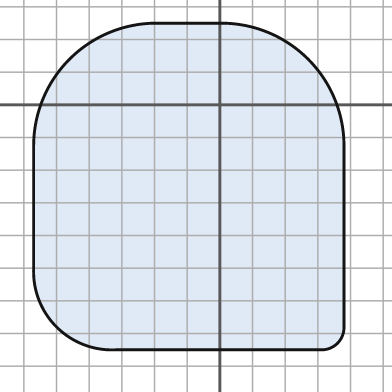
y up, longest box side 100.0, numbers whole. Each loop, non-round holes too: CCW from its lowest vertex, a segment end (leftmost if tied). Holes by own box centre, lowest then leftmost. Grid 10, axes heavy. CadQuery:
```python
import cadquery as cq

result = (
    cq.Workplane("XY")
    .moveTo(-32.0, -75.0)
    .lineTo(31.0, -75.0)
    .threePointArc((36.0, -73.0), (38.0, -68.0))
    .lineTo(38.0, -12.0)
    .threePointArc((27.0, 14.0), (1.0, 25.0))
    .lineTo(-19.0, 25.0)
    .threePointArc((-46.0, 14.0), (-57.0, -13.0))
    .lineTo(-57.0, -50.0)
    .threePointArc((-50.0, -68.0), (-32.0, -75.0))
    .close()
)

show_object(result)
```